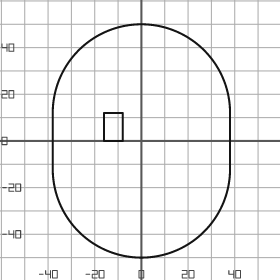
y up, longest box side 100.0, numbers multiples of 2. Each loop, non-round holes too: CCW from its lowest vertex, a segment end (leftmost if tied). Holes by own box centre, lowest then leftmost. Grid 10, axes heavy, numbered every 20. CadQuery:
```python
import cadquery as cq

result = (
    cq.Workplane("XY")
    .moveTo(-38.0, -12.0)
    .threePointArc((0.0, -50.0), (38.0, -12.0))
    .lineTo(38.0, 12.0)
    .threePointArc((0.0, 50.0), (-38.0, 12.0))
    .close()
    .moveTo(-16.0, 0.0)
    .lineTo(-8.0, 0.0)
    .lineTo(-8.0, 12.0)
    .lineTo(-16.0, 12.0)
    .close()
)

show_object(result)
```